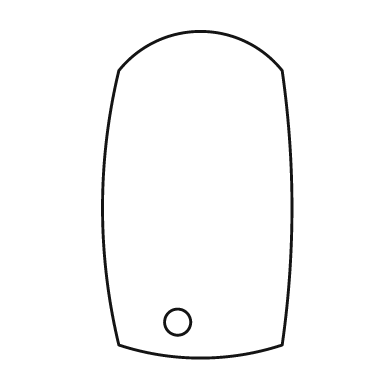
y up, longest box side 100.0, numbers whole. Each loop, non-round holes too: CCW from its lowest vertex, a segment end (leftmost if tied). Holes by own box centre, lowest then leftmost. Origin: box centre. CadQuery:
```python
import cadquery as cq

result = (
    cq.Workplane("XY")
    .moveTo(-24.0, -46.0)
    .threePointArc((1.0, -50.0), (26.0, -46.0))
    .threePointArc((29.0, -4.0), (26.0, 38.0))
    .threePointArc((1.0, 50.0), (-24.0, 38.0))
    .threePointArc((-29.0, -4.0), (-24.0, -46.0))
    .close()
    .moveTo(-6.0, -39.0)
    .circle(4.0)
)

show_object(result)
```